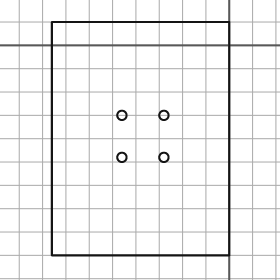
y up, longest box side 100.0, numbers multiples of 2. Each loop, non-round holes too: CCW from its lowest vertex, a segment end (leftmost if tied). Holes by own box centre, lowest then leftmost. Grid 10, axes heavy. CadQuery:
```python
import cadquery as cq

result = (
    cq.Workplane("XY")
    .moveTo(-76.0, -90.0)
    .lineTo(0.0, -90.0)
    .lineTo(0.0, 10.0)
    .lineTo(-76.0, 10.0)
    .close()
    .moveTo(-46.0, -48.0)
    .circle(2.0)
    .moveTo(-28.0, -48.0)
    .circle(2.0)
    .moveTo(-46.0, -30.0)
    .circle(2.0)
    .moveTo(-28.0, -30.0)
    .circle(2.0)
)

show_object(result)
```